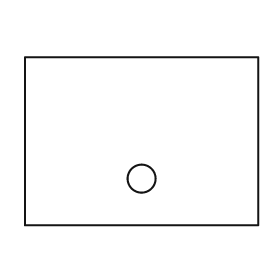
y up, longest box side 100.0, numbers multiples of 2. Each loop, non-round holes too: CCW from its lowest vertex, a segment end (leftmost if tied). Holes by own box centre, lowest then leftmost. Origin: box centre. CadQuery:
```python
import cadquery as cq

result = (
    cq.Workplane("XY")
    .moveTo(-50.0, -36.0)
    .lineTo(50.0, -36.0)
    .lineTo(50.0, 36.0)
    .lineTo(-50.0, 36.0)
    .close()
    .moveTo(0.0, -16.0)
    .circle(6.0)
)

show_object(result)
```